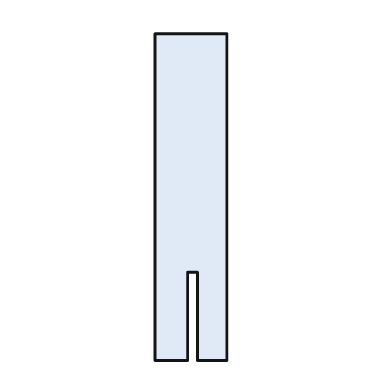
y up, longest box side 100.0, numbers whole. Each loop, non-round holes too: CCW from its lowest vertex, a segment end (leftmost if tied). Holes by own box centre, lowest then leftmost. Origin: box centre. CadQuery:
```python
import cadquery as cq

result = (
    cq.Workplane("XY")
    .moveTo(-11.0, -50.0)
    .lineTo(-1.0, -50.0)
    .lineTo(-1.0, -23.0)
    .lineTo(2.0, -23.0)
    .lineTo(2.0, -50.0)
    .lineTo(11.0, -50.0)
    .lineTo(11.0, 50.0)
    .lineTo(-11.0, 50.0)
    .close()
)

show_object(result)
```